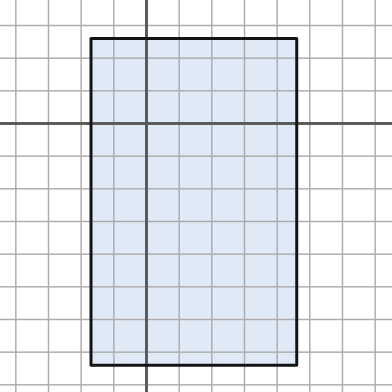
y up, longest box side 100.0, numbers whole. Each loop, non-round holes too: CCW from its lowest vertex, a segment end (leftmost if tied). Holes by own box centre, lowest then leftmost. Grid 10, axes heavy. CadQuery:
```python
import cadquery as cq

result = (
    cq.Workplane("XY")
    .moveTo(-17.0, -74.0)
    .lineTo(46.0, -74.0)
    .lineTo(46.0, 26.0)
    .lineTo(-17.0, 26.0)
    .close()
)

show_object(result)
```